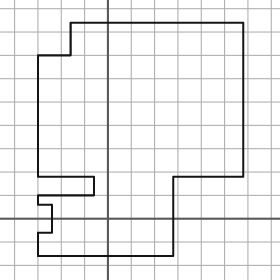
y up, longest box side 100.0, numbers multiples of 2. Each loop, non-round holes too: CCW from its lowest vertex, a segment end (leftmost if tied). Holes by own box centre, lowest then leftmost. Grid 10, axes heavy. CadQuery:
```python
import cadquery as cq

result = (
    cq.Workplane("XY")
    .moveTo(-30.0, -16.0)
    .lineTo(28.0, -16.0)
    .lineTo(28.0, 18.0)
    .lineTo(58.0, 18.0)
    .lineTo(58.0, 84.0)
    .lineTo(-16.0, 84.0)
    .lineTo(-16.0, 70.0)
    .lineTo(-30.0, 70.0)
    .lineTo(-30.0, 18.0)
    .lineTo(-6.0, 18.0)
    .lineTo(-6.0, 10.0)
    .lineTo(-30.0, 10.0)
    .lineTo(-30.0, 6.0)
    .lineTo(-24.0, 6.0)
    .lineTo(-24.0, -6.0)
    .lineTo(-30.0, -6.0)
    .close()
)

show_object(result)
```